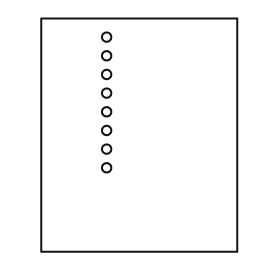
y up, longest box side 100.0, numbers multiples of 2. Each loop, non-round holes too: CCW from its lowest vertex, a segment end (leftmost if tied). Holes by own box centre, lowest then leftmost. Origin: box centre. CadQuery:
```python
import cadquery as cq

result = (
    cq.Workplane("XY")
    .moveTo(-42.0, -50.0)
    .lineTo(42.0, -50.0)
    .lineTo(42.0, 50.0)
    .lineTo(-42.0, 50.0)
    .close()
    .moveTo(-14.0, -14.0)
    .circle(2.0)
    .moveTo(-14.0, -6.0)
    .circle(2.0)
    .moveTo(-14.0, 2.0)
    .circle(2.0)
    .moveTo(-14.0, 10.0)
    .circle(2.0)
    .moveTo(-14.0, 18.0)
    .circle(2.0)
    .moveTo(-14.0, 26.0)
    .circle(2.0)
    .moveTo(-14.0, 34.0)
    .circle(2.0)
    .moveTo(-14.0, 42.0)
    .circle(2.0)
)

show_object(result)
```